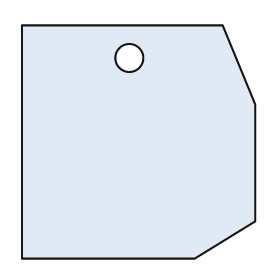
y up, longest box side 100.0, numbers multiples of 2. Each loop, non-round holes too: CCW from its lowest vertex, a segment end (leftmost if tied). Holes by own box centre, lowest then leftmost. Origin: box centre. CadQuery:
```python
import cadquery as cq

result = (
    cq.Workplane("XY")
    .moveTo(-50.0, -50.0)
    .lineTo(24.0, -50.0)
    .lineTo(50.0, -34.0)
    .lineTo(50.0, 16.0)
    .lineTo(36.0, 50.0)
    .lineTo(-50.0, 50.0)
    .close()
    .moveTo(-4.0, 36.0)
    .circle(6.0)
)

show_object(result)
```